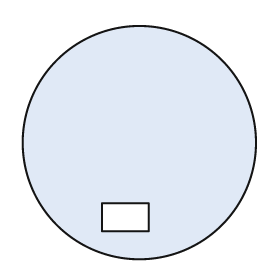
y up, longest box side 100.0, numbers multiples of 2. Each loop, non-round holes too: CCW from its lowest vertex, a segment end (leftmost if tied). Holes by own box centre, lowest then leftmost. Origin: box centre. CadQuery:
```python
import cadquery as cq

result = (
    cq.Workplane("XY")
    .moveTo(0.0, 0.0)
    .circle(50.0)
    .moveTo(-16.0, -38.0)
    .lineTo(4.0, -38.0)
    .lineTo(4.0, -26.0)
    .lineTo(-16.0, -26.0)
    .close()
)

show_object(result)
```